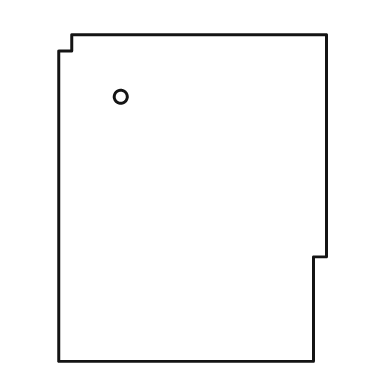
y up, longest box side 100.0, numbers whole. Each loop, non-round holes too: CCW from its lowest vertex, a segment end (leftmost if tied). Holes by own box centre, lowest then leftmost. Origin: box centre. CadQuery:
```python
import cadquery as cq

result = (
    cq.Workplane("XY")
    .moveTo(-41.0, -50.0)
    .lineTo(37.0, -50.0)
    .lineTo(37.0, -18.0)
    .lineTo(41.0, -18.0)
    .lineTo(41.0, 50.0)
    .lineTo(-37.0, 50.0)
    .lineTo(-37.0, 45.0)
    .lineTo(-41.0, 45.0)
    .close()
    .moveTo(-22.0, 31.0)
    .circle(2.0)
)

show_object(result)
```